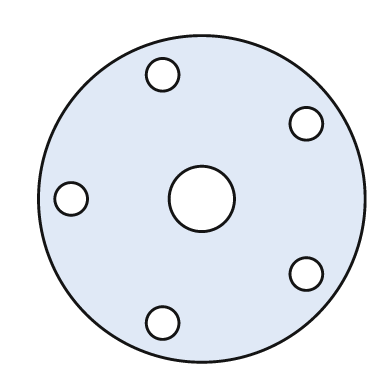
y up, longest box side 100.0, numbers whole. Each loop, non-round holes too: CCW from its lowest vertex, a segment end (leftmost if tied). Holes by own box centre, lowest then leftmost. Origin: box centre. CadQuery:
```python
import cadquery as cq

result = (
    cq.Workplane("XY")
    .moveTo(0.0, 0.0)
    .circle(50.0)
    .moveTo(-12.0, -38.0)
    .circle(5.0)
    .moveTo(32.0, -23.0)
    .circle(5.0)
    .moveTo(-40.0, 0.0)
    .circle(5.0)
    .moveTo(0.0, 0.0)
    .circle(10.0)
    .moveTo(32.0, 23.0)
    .circle(5.0)
    .moveTo(-12.0, 38.0)
    .circle(5.0)
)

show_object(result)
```